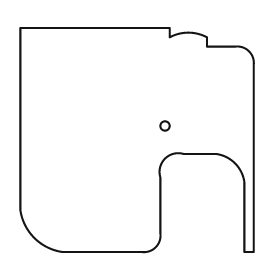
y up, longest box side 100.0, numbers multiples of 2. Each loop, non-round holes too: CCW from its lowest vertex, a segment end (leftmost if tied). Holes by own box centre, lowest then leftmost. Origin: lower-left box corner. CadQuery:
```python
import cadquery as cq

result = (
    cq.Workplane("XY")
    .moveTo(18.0, 0.0)
    .lineTo(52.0, 0.0)
    .threePointArc((58.0, 2.0), (60.0, 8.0))
    .lineTo(60.0, 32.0)
    .threePointArc((62.0, 40.0), (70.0, 42.0))
    .lineTo(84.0, 42.0)
    .threePointArc((92.0, 38.0), (96.0, 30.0))
    .lineTo(96.0, 0.0)
    .lineTo(100.0, 0.0)
    .lineTo(100.0, 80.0)
    .threePointArc((98.0, 86.0), (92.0, 88.0))
    .lineTo(80.0, 88.0)
    .lineTo(80.0, 92.0)
    .threePointArc((72.0, 94.0), (64.0, 92.0))
    .lineTo(64.0, 96.0)
    .lineTo(0.0, 96.0)
    .lineTo(0.0, 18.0)
    .threePointArc((6.0, 6.0), (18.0, 0.0))
    .close()
    .moveTo(62.0, 54.0)
    .circle(2.0)
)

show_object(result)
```